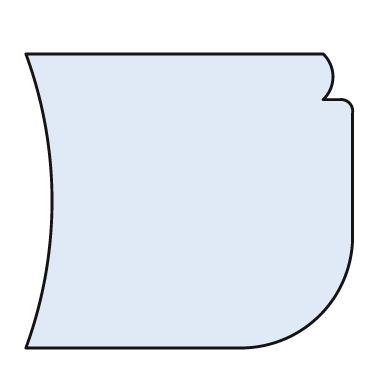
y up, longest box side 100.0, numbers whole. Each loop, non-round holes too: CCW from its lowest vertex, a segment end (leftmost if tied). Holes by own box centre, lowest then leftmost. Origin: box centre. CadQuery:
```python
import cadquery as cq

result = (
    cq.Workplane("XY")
    .moveTo(-50.0, -45.0)
    .lineTo(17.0, -45.0)
    .threePointArc((40.0, -35.0), (50.0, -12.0))
    .lineTo(50.0, 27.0)
    .threePointArc((49.0, 30.0), (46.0, 31.0))
    .lineTo(41.0, 31.0)
    .threePointArc((44.0, 38.0), (41.0, 45.0))
    .lineTo(-50.0, 45.0)
    .threePointArc((-42.0, 0.0), (-50.0, -45.0))
    .close()
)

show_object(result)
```